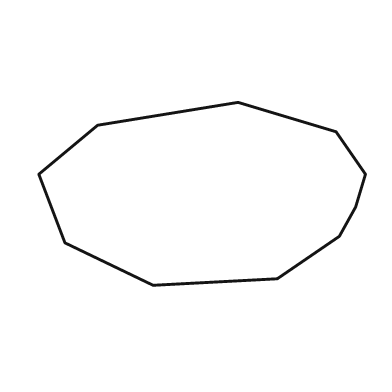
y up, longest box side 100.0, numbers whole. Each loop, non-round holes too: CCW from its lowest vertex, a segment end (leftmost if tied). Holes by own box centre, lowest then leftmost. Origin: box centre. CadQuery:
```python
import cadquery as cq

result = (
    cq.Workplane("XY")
    .moveTo(-15.0, -28.0)
    .lineTo(23.0, -26.0)
    .lineTo(42.0, -13.0)
    .lineTo(47.0, -4.0)
    .lineTo(50.0, 6.0)
    .lineTo(41.0, 19.0)
    .lineTo(11.0, 28.0)
    .lineTo(-32.0, 21.0)
    .lineTo(-50.0, 6.0)
    .lineTo(-42.0, -15.0)
    .close()
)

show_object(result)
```